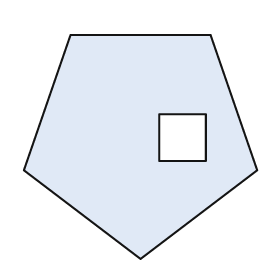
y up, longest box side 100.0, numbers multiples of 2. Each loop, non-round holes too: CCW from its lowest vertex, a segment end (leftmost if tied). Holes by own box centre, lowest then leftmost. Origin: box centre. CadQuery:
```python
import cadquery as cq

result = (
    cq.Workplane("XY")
    .moveTo(0.0, -48.0)
    .lineTo(50.0, -10.0)
    .lineTo(30.0, 48.0)
    .lineTo(-30.0, 48.0)
    .lineTo(-50.0, -10.0)
    .close()
    .moveTo(8.0, -6.0)
    .lineTo(28.0, -6.0)
    .lineTo(28.0, 14.0)
    .lineTo(8.0, 14.0)
    .close()
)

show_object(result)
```